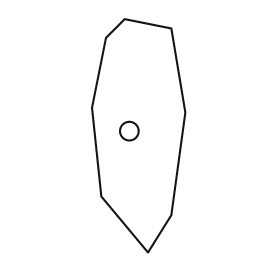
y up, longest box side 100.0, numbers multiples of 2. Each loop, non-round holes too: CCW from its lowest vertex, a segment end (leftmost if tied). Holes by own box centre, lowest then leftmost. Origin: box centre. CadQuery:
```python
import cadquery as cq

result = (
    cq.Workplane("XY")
    .moveTo(4.0, -50.0)
    .lineTo(14.0, -34.0)
    .lineTo(20.0, 10.0)
    .lineTo(14.0, 46.0)
    .lineTo(-6.0, 50.0)
    .lineTo(-14.0, 42.0)
    .lineTo(-20.0, 12.0)
    .lineTo(-16.0, -26.0)
    .close()
    .moveTo(-4.0, 2.0)
    .circle(4.0)
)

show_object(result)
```